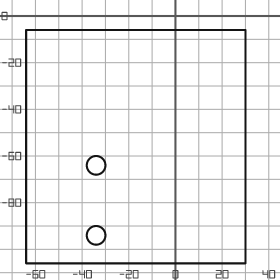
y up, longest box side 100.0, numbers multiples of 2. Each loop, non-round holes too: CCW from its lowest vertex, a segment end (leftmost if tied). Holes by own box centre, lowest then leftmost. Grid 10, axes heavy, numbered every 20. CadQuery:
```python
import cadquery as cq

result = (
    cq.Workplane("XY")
    .moveTo(-64.0, -106.0)
    .lineTo(30.0, -106.0)
    .lineTo(30.0, -6.0)
    .lineTo(-64.0, -6.0)
    .close()
    .moveTo(-34.0, -94.0)
    .circle(4.0)
    .moveTo(-34.0, -64.0)
    .circle(4.0)
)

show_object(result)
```